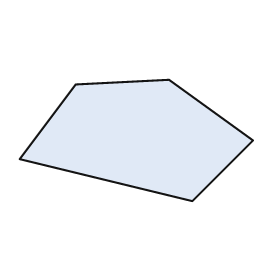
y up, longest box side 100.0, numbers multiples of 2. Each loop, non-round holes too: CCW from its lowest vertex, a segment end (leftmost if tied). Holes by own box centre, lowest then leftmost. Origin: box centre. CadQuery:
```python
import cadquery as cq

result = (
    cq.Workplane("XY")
    .moveTo(24.0, -26.0)
    .lineTo(50.0, 0.0)
    .lineTo(14.0, 26.0)
    .lineTo(-26.0, 24.0)
    .lineTo(-50.0, -8.0)
    .close()
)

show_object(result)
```